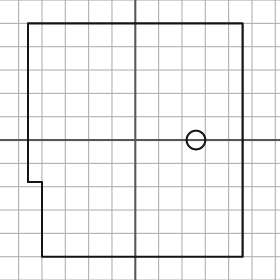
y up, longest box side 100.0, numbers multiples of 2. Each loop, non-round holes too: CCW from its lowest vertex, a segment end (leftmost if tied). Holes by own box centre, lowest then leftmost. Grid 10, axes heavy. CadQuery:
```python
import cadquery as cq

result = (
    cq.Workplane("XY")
    .moveTo(-40.0, -50.0)
    .lineTo(46.0, -50.0)
    .lineTo(46.0, 50.0)
    .lineTo(-46.0, 50.0)
    .lineTo(-46.0, -18.0)
    .lineTo(-40.0, -18.0)
    .close()
    .moveTo(26.0, 0.0)
    .circle(4.0)
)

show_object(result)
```